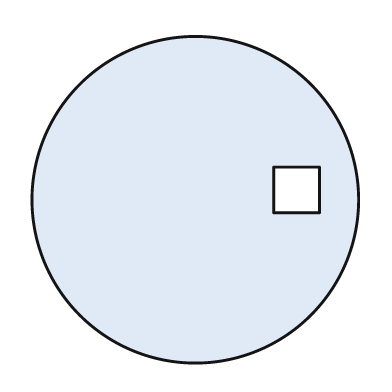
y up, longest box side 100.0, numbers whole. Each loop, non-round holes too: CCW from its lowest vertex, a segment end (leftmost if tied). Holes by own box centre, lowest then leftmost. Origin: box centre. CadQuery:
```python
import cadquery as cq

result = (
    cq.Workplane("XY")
    .moveTo(0.0, 0.0)
    .circle(50.0)
    .moveTo(24.0, -4.0)
    .lineTo(38.0, -4.0)
    .lineTo(38.0, 10.0)
    .lineTo(24.0, 10.0)
    .close()
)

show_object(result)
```